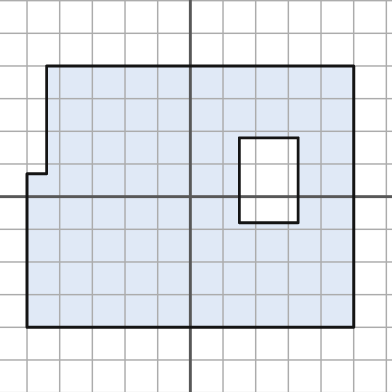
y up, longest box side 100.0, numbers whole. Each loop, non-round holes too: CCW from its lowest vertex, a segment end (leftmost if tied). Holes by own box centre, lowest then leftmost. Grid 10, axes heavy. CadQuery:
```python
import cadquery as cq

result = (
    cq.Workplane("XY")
    .moveTo(-50.0, -40.0)
    .lineTo(50.0, -40.0)
    .lineTo(50.0, 40.0)
    .lineTo(-44.0, 40.0)
    .lineTo(-44.0, 7.0)
    .lineTo(-50.0, 7.0)
    .close()
    .moveTo(15.0, -8.0)
    .lineTo(33.0, -8.0)
    .lineTo(33.0, 18.0)
    .lineTo(15.0, 18.0)
    .close()
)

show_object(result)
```